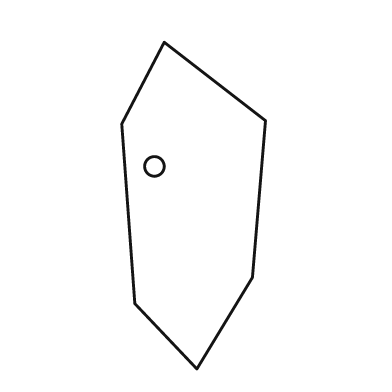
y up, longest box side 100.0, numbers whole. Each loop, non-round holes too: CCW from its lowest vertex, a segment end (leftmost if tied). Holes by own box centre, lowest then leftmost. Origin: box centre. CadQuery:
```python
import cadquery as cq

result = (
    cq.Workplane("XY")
    .moveTo(1.0, -50.0)
    .lineTo(18.0, -22.0)
    .lineTo(22.0, 26.0)
    .lineTo(-9.0, 50.0)
    .lineTo(-22.0, 25.0)
    .lineTo(-18.0, -30.0)
    .close()
    .moveTo(-12.0, 12.0)
    .circle(3.0)
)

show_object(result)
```